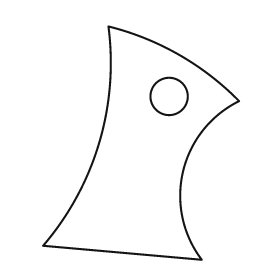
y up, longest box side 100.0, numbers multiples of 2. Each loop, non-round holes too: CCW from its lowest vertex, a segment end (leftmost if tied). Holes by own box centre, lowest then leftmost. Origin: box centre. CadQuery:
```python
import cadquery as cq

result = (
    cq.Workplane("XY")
    .moveTo(26.0, -50.0)
    .threePointArc((18.0, -12.0), (42.0, 18.0))
    .threePointArc((16.0, 38.0), (-14.0, 50.0))
    .threePointArc((-18.0, 0.0), (-42.0, -44.0))
    .close()
    .moveTo(12.0, 20.0)
    .circle(8.0)
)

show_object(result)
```